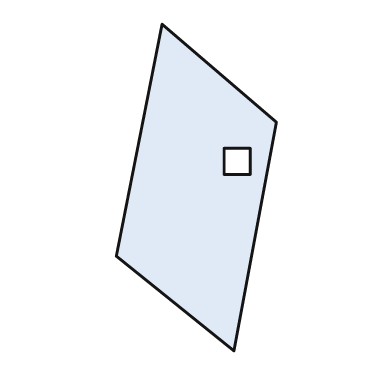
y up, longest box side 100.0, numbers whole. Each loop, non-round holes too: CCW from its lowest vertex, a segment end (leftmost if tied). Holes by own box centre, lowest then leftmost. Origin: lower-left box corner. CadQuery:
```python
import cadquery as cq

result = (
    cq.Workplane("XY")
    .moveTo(36.0, 0.0)
    .lineTo(49.0, 70.0)
    .lineTo(14.0, 100.0)
    .lineTo(0.0, 29.0)
    .close()
    .moveTo(33.0, 54.0)
    .lineTo(41.0, 54.0)
    .lineTo(41.0, 62.0)
    .lineTo(33.0, 62.0)
    .close()
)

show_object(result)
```